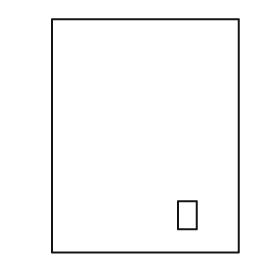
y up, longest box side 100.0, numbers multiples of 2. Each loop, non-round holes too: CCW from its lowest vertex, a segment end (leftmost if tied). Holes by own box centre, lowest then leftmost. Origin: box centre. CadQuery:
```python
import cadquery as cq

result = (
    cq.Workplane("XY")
    .moveTo(-40.0, -50.0)
    .lineTo(40.0, -50.0)
    .lineTo(40.0, 50.0)
    .lineTo(-40.0, 50.0)
    .close()
    .moveTo(14.0, -40.0)
    .lineTo(22.0, -40.0)
    .lineTo(22.0, -28.0)
    .lineTo(14.0, -28.0)
    .close()
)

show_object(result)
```